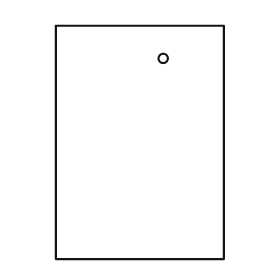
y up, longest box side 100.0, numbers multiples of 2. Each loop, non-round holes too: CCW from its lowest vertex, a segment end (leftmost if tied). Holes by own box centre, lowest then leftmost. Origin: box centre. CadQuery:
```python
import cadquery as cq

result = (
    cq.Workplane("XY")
    .moveTo(-36.0, -50.0)
    .lineTo(36.0, -50.0)
    .lineTo(36.0, 50.0)
    .lineTo(-36.0, 50.0)
    .close()
    .moveTo(10.0, 36.0)
    .circle(2.0)
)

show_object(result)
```